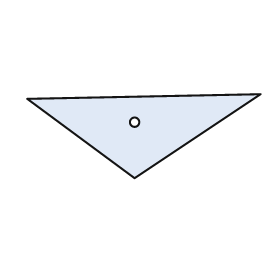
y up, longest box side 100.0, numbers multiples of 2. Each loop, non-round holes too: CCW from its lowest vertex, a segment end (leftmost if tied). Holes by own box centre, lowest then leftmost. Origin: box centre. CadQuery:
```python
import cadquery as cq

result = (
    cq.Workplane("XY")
    .moveTo(-4.0, -18.0)
    .lineTo(50.0, 18.0)
    .lineTo(-50.0, 16.0)
    .close()
    .moveTo(-4.0, 6.0)
    .circle(2.0)
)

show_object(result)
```